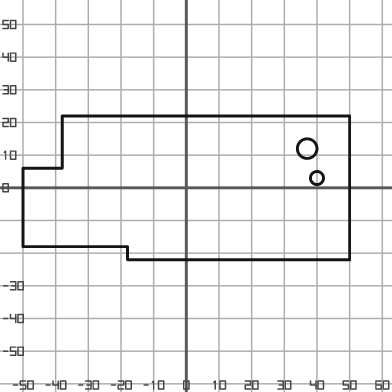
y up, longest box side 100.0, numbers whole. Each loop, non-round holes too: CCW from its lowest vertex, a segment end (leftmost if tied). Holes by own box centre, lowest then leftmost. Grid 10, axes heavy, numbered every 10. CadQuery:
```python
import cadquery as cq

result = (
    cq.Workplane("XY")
    .moveTo(-18.0, -22.0)
    .lineTo(50.0, -22.0)
    .lineTo(50.0, 22.0)
    .lineTo(-38.0, 22.0)
    .lineTo(-38.0, 6.0)
    .lineTo(-50.0, 6.0)
    .lineTo(-50.0, -18.0)
    .lineTo(-18.0, -18.0)
    .close()
    .moveTo(40.0, 3.0)
    .circle(2.0)
    .moveTo(37.0, 12.0)
    .circle(3.0)
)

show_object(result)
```